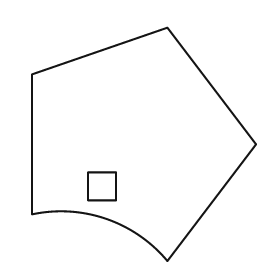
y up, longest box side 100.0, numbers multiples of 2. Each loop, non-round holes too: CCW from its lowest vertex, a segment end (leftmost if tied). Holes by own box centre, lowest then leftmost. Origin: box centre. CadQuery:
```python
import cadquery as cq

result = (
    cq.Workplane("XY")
    .moveTo(10.0, -50.0)
    .lineTo(48.0, 0.0)
    .lineTo(10.0, 50.0)
    .lineTo(-48.0, 30.0)
    .lineTo(-48.0, -30.0)
    .threePointArc((-16.0, -32.0), (10.0, -50.0))
    .close()
    .moveTo(-24.0, -24.0)
    .lineTo(-12.0, -24.0)
    .lineTo(-12.0, -12.0)
    .lineTo(-24.0, -12.0)
    .close()
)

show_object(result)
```